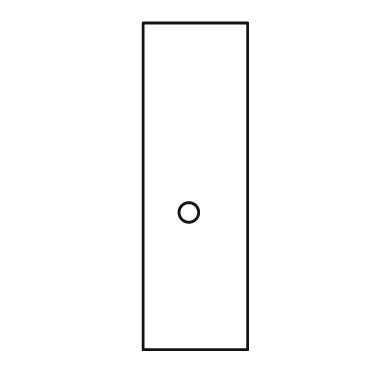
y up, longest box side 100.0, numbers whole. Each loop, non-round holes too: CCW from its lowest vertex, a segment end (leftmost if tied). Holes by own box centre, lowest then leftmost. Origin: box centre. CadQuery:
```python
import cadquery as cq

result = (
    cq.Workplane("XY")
    .moveTo(-16.0, -50.0)
    .lineTo(16.0, -50.0)
    .lineTo(16.0, 50.0)
    .lineTo(-16.0, 50.0)
    .close()
    .moveTo(-2.0, -8.0)
    .circle(3.0)
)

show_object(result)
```